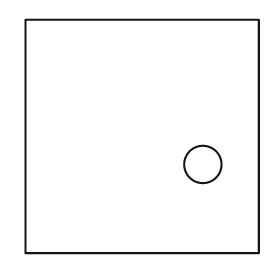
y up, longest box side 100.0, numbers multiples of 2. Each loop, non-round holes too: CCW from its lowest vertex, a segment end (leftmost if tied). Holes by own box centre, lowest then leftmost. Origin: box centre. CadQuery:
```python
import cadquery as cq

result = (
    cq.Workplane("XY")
    .moveTo(-50.0, -50.0)
    .lineTo(50.0, -50.0)
    .lineTo(50.0, 50.0)
    .lineTo(-50.0, 50.0)
    .close()
    .moveTo(26.0, -12.0)
    .circle(8.0)
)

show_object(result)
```